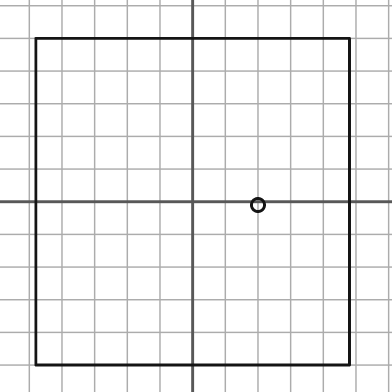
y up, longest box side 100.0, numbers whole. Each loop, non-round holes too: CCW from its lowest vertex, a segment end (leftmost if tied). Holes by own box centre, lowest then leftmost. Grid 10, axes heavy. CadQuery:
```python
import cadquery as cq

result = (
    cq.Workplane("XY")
    .moveTo(-48.0, -50.0)
    .lineTo(48.0, -50.0)
    .lineTo(48.0, 50.0)
    .lineTo(-48.0, 50.0)
    .close()
    .moveTo(20.0, -1.0)
    .circle(2.0)
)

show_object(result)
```